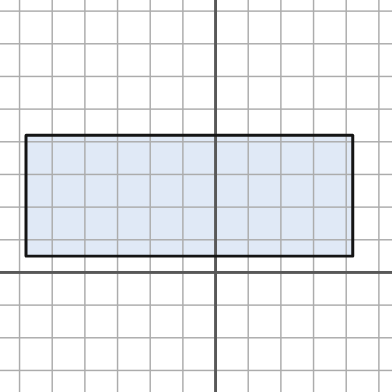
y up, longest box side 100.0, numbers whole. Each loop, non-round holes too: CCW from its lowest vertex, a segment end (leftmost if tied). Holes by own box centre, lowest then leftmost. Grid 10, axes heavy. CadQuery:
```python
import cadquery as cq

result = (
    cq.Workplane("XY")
    .moveTo(-58.0, 5.0)
    .lineTo(42.0, 5.0)
    .lineTo(42.0, 42.0)
    .lineTo(-58.0, 42.0)
    .close()
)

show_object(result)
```